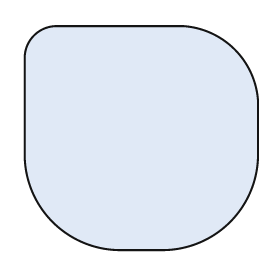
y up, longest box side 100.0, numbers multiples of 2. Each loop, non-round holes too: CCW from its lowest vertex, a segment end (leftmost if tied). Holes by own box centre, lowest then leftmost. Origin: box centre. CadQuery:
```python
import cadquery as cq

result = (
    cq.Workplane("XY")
    .moveTo(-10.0, -48.0)
    .lineTo(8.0, -48.0)
    .threePointArc((38.0, -36.0), (50.0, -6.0))
    .lineTo(50.0, 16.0)
    .threePointArc((40.0, 38.0), (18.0, 48.0))
    .lineTo(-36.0, 48.0)
    .threePointArc((-46.0, 44.0), (-50.0, 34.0))
    .lineTo(-50.0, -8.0)
    .threePointArc((-38.0, -36.0), (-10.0, -48.0))
    .close()
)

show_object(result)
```